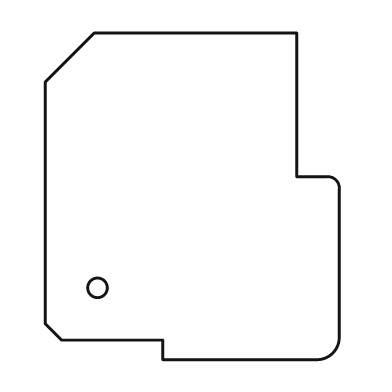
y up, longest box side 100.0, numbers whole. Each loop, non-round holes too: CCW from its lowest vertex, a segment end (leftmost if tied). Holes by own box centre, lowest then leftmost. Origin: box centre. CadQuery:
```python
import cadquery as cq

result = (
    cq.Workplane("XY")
    .moveTo(-9.0, -50.0)
    .lineTo(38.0, -50.0)
    .threePointArc((43.0, -48.0), (45.0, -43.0))
    .lineTo(45.0, 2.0)
    .threePointArc((44.0, 5.0), (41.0, 6.0))
    .lineTo(32.0, 6.0)
    .lineTo(32.0, 50.0)
    .lineTo(-30.0, 50.0)
    .lineTo(-45.0, 35.0)
    .lineTo(-45.0, -39.0)
    .lineTo(-40.0, -44.0)
    .lineTo(-9.0, -44.0)
    .close()
    .moveTo(-29.0, -28.0)
    .circle(3.0)
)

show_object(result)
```